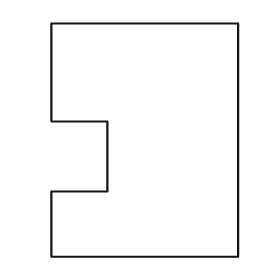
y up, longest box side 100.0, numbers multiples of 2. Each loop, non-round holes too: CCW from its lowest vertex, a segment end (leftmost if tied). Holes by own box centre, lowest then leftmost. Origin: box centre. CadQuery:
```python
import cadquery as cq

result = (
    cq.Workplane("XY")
    .moveTo(-40.0, -50.0)
    .lineTo(40.0, -50.0)
    .lineTo(40.0, 50.0)
    .lineTo(-40.0, 50.0)
    .lineTo(-40.0, 8.0)
    .lineTo(-16.0, 8.0)
    .lineTo(-16.0, -22.0)
    .lineTo(-40.0, -22.0)
    .close()
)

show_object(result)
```